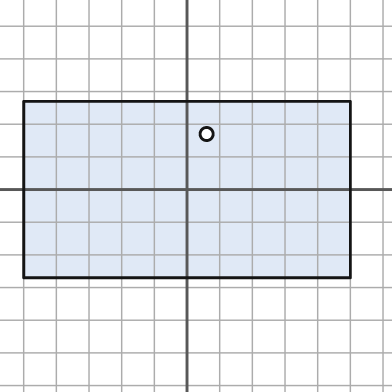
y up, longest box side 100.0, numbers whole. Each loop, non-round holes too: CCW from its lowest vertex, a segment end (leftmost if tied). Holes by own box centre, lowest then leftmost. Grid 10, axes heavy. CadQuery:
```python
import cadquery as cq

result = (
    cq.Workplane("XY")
    .moveTo(-50.0, -27.0)
    .lineTo(50.0, -27.0)
    .lineTo(50.0, 27.0)
    .lineTo(-50.0, 27.0)
    .close()
    .moveTo(6.0, 17.0)
    .circle(2.0)
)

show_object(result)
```